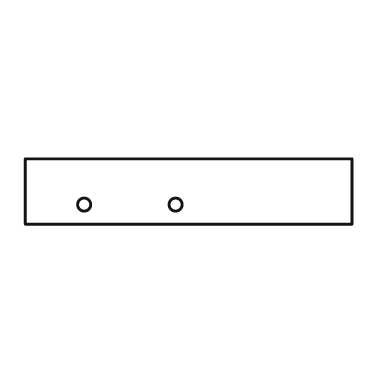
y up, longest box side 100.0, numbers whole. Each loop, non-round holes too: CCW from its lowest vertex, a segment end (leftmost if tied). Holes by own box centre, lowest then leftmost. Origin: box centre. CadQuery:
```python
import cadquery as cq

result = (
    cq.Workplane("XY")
    .moveTo(-50.0, -10.0)
    .lineTo(50.0, -10.0)
    .lineTo(50.0, 10.0)
    .lineTo(-50.0, 10.0)
    .close()
    .moveTo(-32.0, -4.0)
    .circle(2.0)
    .moveTo(-4.0, -4.0)
    .circle(2.0)
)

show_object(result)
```